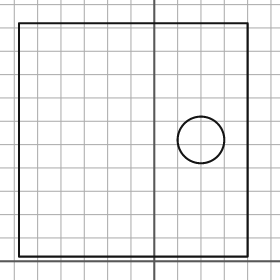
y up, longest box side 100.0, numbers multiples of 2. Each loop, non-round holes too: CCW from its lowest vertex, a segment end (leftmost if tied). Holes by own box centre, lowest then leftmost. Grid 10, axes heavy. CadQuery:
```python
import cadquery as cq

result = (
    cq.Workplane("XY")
    .moveTo(-58.0, 2.0)
    .lineTo(40.0, 2.0)
    .lineTo(40.0, 102.0)
    .lineTo(-58.0, 102.0)
    .close()
    .moveTo(20.0, 52.0)
    .circle(10.0)
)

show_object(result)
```